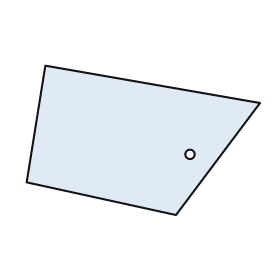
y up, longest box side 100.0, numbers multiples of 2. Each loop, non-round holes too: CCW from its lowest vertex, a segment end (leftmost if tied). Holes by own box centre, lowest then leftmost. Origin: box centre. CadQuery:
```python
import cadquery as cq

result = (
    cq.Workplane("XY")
    .moveTo(14.0, -32.0)
    .lineTo(50.0, 16.0)
    .lineTo(-42.0, 32.0)
    .lineTo(-50.0, -18.0)
    .close()
    .moveTo(20.0, -6.0)
    .circle(2.0)
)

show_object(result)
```